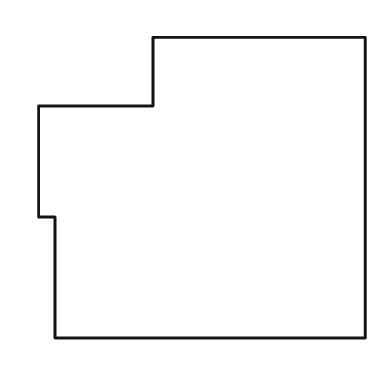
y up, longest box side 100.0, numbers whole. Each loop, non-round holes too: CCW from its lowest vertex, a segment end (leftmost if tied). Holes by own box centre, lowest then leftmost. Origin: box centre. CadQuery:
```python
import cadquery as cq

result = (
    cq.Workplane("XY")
    .moveTo(-45.0, -46.0)
    .lineTo(50.0, -46.0)
    .lineTo(50.0, 46.0)
    .lineTo(-15.0, 46.0)
    .lineTo(-15.0, 25.0)
    .lineTo(-50.0, 25.0)
    .lineTo(-50.0, -9.0)
    .lineTo(-45.0, -9.0)
    .close()
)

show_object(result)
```